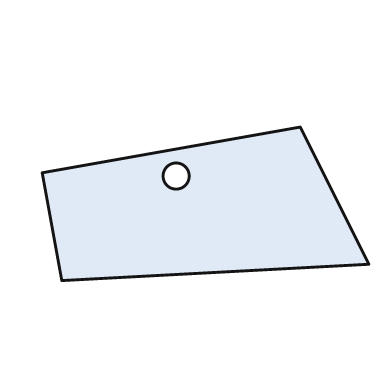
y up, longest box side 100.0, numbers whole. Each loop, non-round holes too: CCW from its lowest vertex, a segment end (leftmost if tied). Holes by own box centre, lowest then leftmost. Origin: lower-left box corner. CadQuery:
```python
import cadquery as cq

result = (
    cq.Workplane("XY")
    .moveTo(6.0, 0.0)
    .lineTo(100.0, 5.0)
    .lineTo(79.0, 47.0)
    .lineTo(0.0, 33.0)
    .close()
    .moveTo(41.0, 32.0)
    .circle(4.0)
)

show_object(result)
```